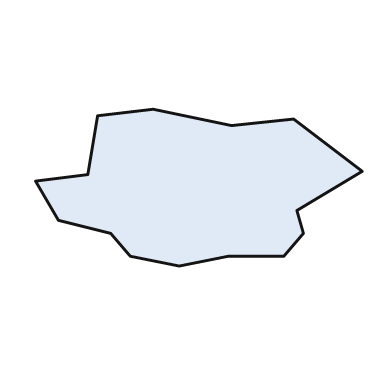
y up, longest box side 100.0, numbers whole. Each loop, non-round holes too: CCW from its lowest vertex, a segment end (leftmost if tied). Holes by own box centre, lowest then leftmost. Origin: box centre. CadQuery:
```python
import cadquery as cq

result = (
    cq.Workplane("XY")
    .moveTo(-6.0, -24.0)
    .lineTo(9.0, -21.0)
    .lineTo(26.0, -21.0)
    .lineTo(32.0, -14.0)
    .lineTo(30.0, -7.0)
    .lineTo(50.0, 5.0)
    .lineTo(29.0, 21.0)
    .lineTo(10.0, 19.0)
    .lineTo(-14.0, 24.0)
    .lineTo(-31.0, 22.0)
    .lineTo(-34.0, 4.0)
    .lineTo(-50.0, 2.0)
    .lineTo(-43.0, -10.0)
    .lineTo(-27.0, -14.0)
    .lineTo(-21.0, -21.0)
    .close()
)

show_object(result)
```